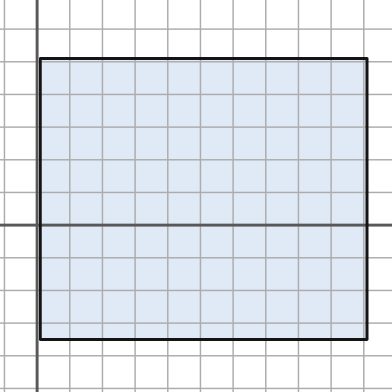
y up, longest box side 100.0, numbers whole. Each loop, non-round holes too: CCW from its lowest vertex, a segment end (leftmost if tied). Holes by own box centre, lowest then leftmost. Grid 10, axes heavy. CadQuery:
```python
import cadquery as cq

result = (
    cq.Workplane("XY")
    .moveTo(1.0, -35.0)
    .lineTo(101.0, -35.0)
    .lineTo(101.0, 51.0)
    .lineTo(1.0, 51.0)
    .close()
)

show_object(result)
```